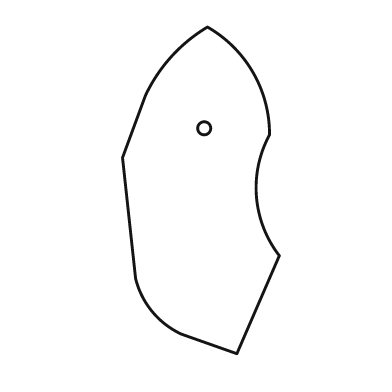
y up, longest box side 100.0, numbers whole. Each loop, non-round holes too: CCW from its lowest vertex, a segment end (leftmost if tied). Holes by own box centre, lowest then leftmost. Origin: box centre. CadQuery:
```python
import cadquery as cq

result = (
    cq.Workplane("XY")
    .moveTo(11.0, -50.0)
    .lineTo(24.0, -20.0)
    .threePointArc((17.0, -2.0), (21.0, 17.0))
    .threePointArc((16.0, 36.0), (2.0, 50.0))
    .threePointArc((-9.0, 41.0), (-17.0, 29.0))
    .lineTo(-24.0, 10.0)
    .lineTo(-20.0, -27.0)
    .threePointArc((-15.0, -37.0), (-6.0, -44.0))
    .close()
    .moveTo(1.0, 19.0)
    .circle(2.0)
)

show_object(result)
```